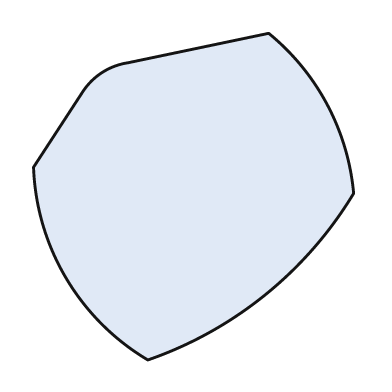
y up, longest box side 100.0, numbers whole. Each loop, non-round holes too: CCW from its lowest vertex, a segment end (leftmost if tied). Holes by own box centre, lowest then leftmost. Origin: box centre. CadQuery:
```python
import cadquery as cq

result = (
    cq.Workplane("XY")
    .moveTo(-14.0, -50.0)
    .threePointArc((22.0, -30.0), (49.0, 1.0))
    .threePointArc((41.0, 28.0), (23.0, 50.0))
    .lineTo(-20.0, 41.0)
    .threePointArc((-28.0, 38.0), (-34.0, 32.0))
    .lineTo(-49.0, 9.0)
    .threePointArc((-39.0, -25.0), (-14.0, -50.0))
    .close()
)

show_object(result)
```